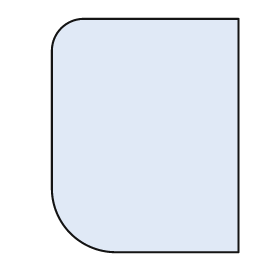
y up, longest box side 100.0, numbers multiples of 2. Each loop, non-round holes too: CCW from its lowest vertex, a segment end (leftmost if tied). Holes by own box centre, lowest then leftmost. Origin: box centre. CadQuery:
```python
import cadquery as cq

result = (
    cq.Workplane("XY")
    .moveTo(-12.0, -50.0)
    .lineTo(40.0, -50.0)
    .lineTo(40.0, 50.0)
    .lineTo(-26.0, 50.0)
    .threePointArc((-36.0, 46.0), (-40.0, 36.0))
    .lineTo(-40.0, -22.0)
    .threePointArc((-32.0, -42.0), (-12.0, -50.0))
    .close()
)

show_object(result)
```